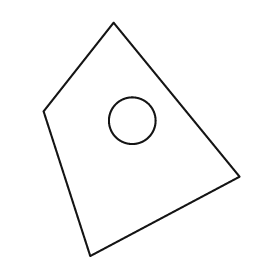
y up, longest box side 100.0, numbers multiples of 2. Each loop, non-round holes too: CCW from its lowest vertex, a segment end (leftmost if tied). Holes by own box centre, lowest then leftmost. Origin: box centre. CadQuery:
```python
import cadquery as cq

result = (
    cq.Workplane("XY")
    .moveTo(-22.0, -50.0)
    .lineTo(42.0, -16.0)
    .lineTo(-12.0, 50.0)
    .lineTo(-42.0, 12.0)
    .close()
    .moveTo(-4.0, 8.0)
    .circle(10.0)
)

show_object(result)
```